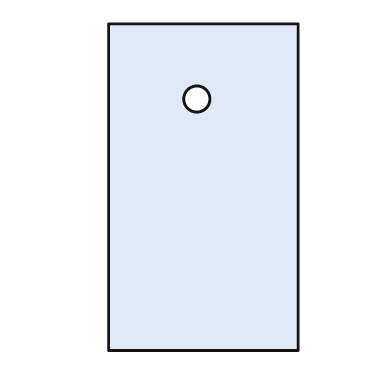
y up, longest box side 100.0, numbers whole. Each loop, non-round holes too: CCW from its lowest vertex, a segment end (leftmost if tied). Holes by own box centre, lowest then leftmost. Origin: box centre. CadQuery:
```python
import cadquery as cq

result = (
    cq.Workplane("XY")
    .moveTo(-29.0, -50.0)
    .lineTo(29.0, -50.0)
    .lineTo(29.0, 50.0)
    .lineTo(-29.0, 50.0)
    .close()
    .moveTo(-2.0, 27.0)
    .circle(4.0)
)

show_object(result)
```